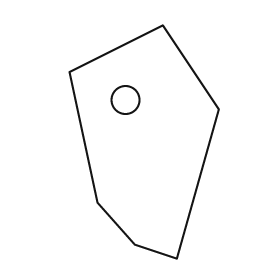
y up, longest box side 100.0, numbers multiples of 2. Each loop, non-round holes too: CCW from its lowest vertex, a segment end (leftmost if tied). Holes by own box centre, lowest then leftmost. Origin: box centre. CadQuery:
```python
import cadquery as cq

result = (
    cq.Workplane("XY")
    .moveTo(14.0, -50.0)
    .lineTo(32.0, 14.0)
    .lineTo(8.0, 50.0)
    .lineTo(-32.0, 30.0)
    .lineTo(-20.0, -26.0)
    .lineTo(-4.0, -44.0)
    .close()
    .moveTo(-8.0, 18.0)
    .circle(6.0)
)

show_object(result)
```